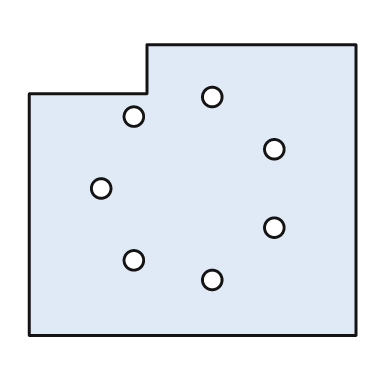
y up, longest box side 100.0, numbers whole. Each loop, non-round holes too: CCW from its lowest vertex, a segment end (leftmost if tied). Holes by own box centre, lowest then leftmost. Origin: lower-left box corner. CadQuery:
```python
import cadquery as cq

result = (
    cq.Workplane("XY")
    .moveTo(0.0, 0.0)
    .lineTo(100.0, 0.0)
    .lineTo(100.0, 89.0)
    .lineTo(36.0, 89.0)
    .lineTo(36.0, 74.0)
    .lineTo(0.0, 74.0)
    .close()
    .moveTo(56.0, 17.0)
    .circle(3.0)
    .moveTo(32.0, 23.0)
    .circle(3.0)
    .moveTo(75.0, 33.0)
    .circle(3.0)
    .moveTo(22.0, 45.0)
    .circle(3.0)
    .moveTo(75.0, 57.0)
    .circle(3.0)
    .moveTo(32.0, 67.0)
    .circle(3.0)
    .moveTo(56.0, 73.0)
    .circle(3.0)
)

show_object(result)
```